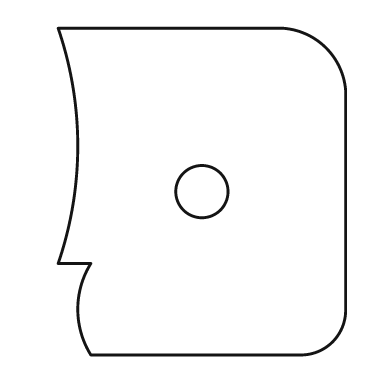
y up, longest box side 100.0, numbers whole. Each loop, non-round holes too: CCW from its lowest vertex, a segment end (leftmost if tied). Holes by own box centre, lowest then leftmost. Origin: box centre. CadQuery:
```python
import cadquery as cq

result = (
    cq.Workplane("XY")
    .moveTo(-34.0, -50.0)
    .lineTo(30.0, -50.0)
    .threePointArc((40.0, -46.0), (44.0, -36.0))
    .lineTo(44.0, 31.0)
    .threePointArc((38.0, 44.0), (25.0, 50.0))
    .lineTo(-44.0, 50.0)
    .threePointArc((-38.0, 14.0), (-44.0, -22.0))
    .lineTo(-34.0, -22.0)
    .threePointArc((-38.0, -36.0), (-34.0, -50.0))
    .close()
    .moveTo(0.0, 0.0)
    .circle(8.0)
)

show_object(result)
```